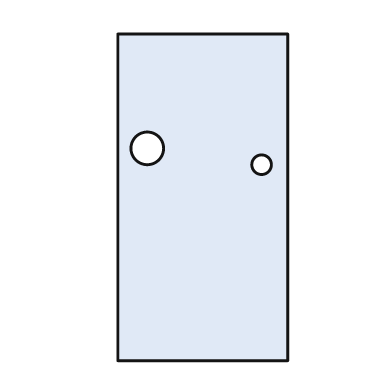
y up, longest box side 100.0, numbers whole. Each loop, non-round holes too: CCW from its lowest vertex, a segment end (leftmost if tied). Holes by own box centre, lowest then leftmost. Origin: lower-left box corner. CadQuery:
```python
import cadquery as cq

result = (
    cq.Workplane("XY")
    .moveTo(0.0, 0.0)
    .lineTo(52.0, 0.0)
    .lineTo(52.0, 100.0)
    .lineTo(0.0, 100.0)
    .close()
    .moveTo(44.0, 60.0)
    .circle(3.0)
    .moveTo(9.0, 65.0)
    .circle(5.0)
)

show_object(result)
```